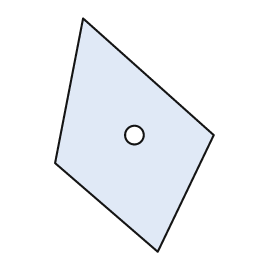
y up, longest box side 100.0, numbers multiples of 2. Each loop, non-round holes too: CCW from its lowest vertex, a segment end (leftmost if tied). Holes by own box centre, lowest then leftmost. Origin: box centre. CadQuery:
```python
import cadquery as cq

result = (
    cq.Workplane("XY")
    .moveTo(10.0, -50.0)
    .lineTo(34.0, 0.0)
    .lineTo(-22.0, 50.0)
    .lineTo(-34.0, -12.0)
    .close()
    .moveTo(0.0, 0.0)
    .circle(4.0)
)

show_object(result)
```